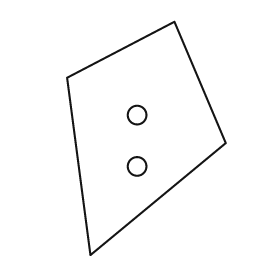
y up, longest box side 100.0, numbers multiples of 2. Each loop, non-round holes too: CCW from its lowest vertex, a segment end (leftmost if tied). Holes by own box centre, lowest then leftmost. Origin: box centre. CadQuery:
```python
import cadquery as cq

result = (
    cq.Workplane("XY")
    .moveTo(-24.0, -50.0)
    .lineTo(34.0, -2.0)
    .lineTo(12.0, 50.0)
    .lineTo(-34.0, 26.0)
    .close()
    .moveTo(-4.0, -12.0)
    .circle(4.0)
    .moveTo(-4.0, 10.0)
    .circle(4.0)
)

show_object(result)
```